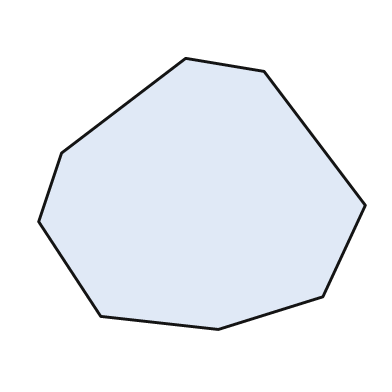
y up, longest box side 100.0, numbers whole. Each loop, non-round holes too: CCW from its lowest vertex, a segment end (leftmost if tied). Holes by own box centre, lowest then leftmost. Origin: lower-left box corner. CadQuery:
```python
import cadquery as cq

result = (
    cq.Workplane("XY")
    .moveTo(55.0, 0.0)
    .lineTo(87.0, 10.0)
    .lineTo(100.0, 38.0)
    .lineTo(69.0, 79.0)
    .lineTo(45.0, 83.0)
    .lineTo(7.0, 54.0)
    .lineTo(0.0, 33.0)
    .lineTo(19.0, 4.0)
    .close()
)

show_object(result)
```